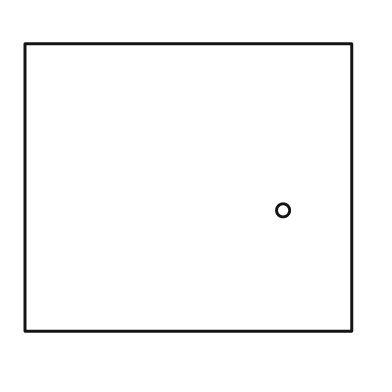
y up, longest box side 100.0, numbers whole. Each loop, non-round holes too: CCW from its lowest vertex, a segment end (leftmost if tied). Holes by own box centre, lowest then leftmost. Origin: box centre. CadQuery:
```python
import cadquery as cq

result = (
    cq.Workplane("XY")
    .moveTo(-50.0, -44.0)
    .lineTo(50.0, -44.0)
    .lineTo(50.0, 44.0)
    .lineTo(-50.0, 44.0)
    .close()
    .moveTo(29.0, -7.0)
    .circle(2.0)
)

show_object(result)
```